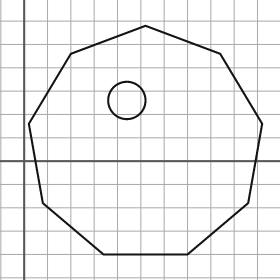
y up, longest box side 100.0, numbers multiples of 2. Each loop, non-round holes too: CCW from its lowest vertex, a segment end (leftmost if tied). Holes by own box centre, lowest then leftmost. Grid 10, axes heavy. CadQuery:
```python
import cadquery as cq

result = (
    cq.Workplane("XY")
    .moveTo(34.0, -40.0)
    .lineTo(70.0, -40.0)
    .lineTo(96.0, -18.0)
    .lineTo(102.0, 16.0)
    .lineTo(84.0, 46.0)
    .lineTo(52.0, 58.0)
    .lineTo(20.0, 46.0)
    .lineTo(2.0, 16.0)
    .lineTo(8.0, -18.0)
    .close()
    .moveTo(44.0, 26.0)
    .circle(8.0)
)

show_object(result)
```